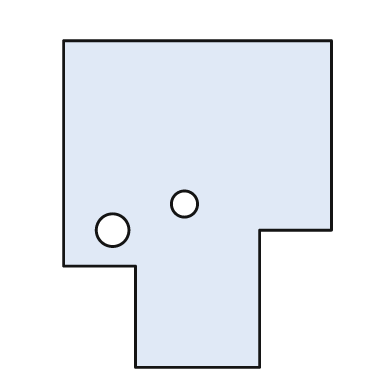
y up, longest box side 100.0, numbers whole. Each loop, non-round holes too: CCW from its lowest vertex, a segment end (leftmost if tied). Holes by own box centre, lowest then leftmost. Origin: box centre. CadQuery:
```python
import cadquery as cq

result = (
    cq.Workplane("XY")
    .moveTo(-19.0, -50.0)
    .lineTo(19.0, -50.0)
    .lineTo(19.0, -8.0)
    .lineTo(41.0, -8.0)
    .lineTo(41.0, 50.0)
    .lineTo(-41.0, 50.0)
    .lineTo(-41.0, -19.0)
    .lineTo(-19.0, -19.0)
    .close()
    .moveTo(-26.0, -8.0)
    .circle(5.0)
    .moveTo(-4.0, 0.0)
    .circle(4.0)
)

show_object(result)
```